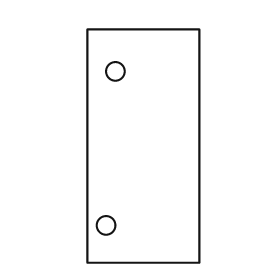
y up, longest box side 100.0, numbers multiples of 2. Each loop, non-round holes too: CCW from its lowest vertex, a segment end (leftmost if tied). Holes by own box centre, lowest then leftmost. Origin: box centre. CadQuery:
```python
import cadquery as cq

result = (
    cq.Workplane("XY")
    .moveTo(-24.0, -50.0)
    .lineTo(24.0, -50.0)
    .lineTo(24.0, 50.0)
    .lineTo(-24.0, 50.0)
    .close()
    .moveTo(-16.0, -34.0)
    .circle(4.0)
    .moveTo(-12.0, 32.0)
    .circle(4.0)
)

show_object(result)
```